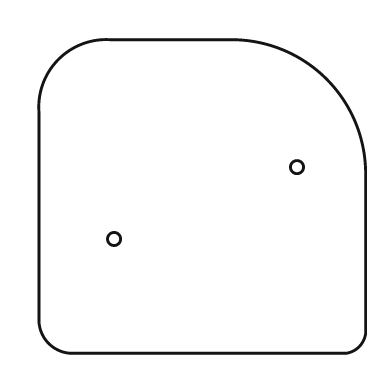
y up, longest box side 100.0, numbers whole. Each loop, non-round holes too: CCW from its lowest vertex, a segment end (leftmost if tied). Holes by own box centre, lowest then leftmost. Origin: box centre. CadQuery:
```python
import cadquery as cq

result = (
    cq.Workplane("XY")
    .moveTo(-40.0, -48.0)
    .lineTo(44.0, -48.0)
    .threePointArc((48.0, -46.0), (50.0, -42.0))
    .lineTo(50.0, 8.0)
    .threePointArc((38.0, 36.0), (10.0, 48.0))
    .lineTo(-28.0, 48.0)
    .threePointArc((-44.0, 42.0), (-50.0, 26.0))
    .lineTo(-50.0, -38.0)
    .threePointArc((-47.0, -45.0), (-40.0, -48.0))
    .close()
    .moveTo(-27.0, -13.0)
    .circle(2.0)
    .moveTo(29.0, 9.0)
    .circle(2.0)
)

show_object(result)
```